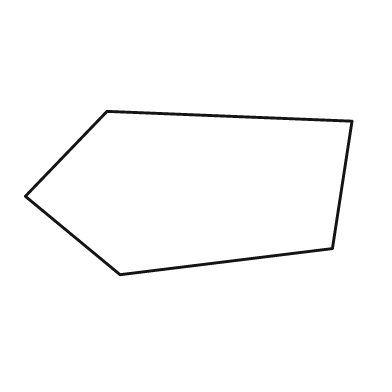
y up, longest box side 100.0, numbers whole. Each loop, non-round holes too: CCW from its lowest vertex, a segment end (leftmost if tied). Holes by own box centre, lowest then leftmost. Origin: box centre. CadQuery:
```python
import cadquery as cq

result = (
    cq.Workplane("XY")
    .moveTo(-21.0, -25.0)
    .lineTo(44.0, -17.0)
    .lineTo(50.0, 22.0)
    .lineTo(-25.0, 25.0)
    .lineTo(-50.0, -1.0)
    .close()
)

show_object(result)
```